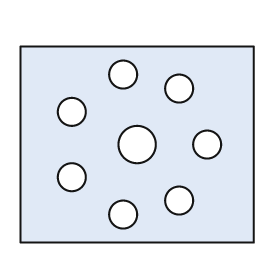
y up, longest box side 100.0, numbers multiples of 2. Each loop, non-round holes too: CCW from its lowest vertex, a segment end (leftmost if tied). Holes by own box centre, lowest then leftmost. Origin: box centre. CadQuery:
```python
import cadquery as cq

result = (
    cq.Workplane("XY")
    .moveTo(-50.0, -42.0)
    .lineTo(50.0, -42.0)
    .lineTo(50.0, 42.0)
    .lineTo(-50.0, 42.0)
    .close()
    .moveTo(-6.0, -30.0)
    .circle(6.0)
    .moveTo(18.0, -24.0)
    .circle(6.0)
    .moveTo(-28.0, -14.0)
    .circle(6.0)
    .moveTo(0.0, 0.0)
    .circle(8.0)
    .moveTo(30.0, 0.0)
    .circle(6.0)
    .moveTo(-28.0, 14.0)
    .circle(6.0)
    .moveTo(18.0, 24.0)
    .circle(6.0)
    .moveTo(-6.0, 30.0)
    .circle(6.0)
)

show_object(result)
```